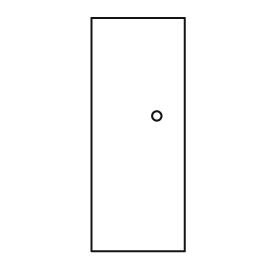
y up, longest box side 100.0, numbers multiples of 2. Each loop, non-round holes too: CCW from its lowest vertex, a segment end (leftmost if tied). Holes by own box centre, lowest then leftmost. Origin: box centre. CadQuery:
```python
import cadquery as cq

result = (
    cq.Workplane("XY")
    .moveTo(-20.0, -50.0)
    .lineTo(20.0, -50.0)
    .lineTo(20.0, 50.0)
    .lineTo(-20.0, 50.0)
    .close()
    .moveTo(8.0, 8.0)
    .circle(2.0)
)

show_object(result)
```